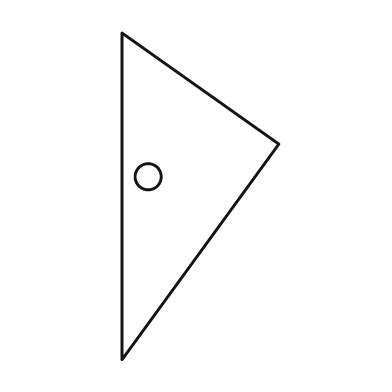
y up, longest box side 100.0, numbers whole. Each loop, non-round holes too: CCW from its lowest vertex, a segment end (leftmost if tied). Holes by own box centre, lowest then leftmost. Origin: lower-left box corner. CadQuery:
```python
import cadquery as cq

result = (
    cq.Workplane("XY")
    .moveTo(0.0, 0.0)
    .lineTo(48.0, 66.0)
    .lineTo(0.0, 100.0)
    .close()
    .moveTo(8.0, 56.0)
    .circle(4.0)
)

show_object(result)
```